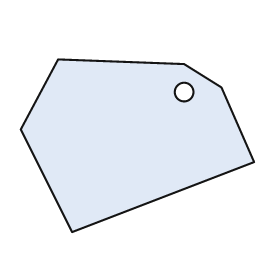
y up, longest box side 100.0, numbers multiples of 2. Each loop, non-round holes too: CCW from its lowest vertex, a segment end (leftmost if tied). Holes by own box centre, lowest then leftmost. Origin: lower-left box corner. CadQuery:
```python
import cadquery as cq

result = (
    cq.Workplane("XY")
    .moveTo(22.0, 0.0)
    .lineTo(100.0, 30.0)
    .lineTo(86.0, 62.0)
    .lineTo(70.0, 72.0)
    .lineTo(16.0, 74.0)
    .lineTo(0.0, 44.0)
    .close()
    .moveTo(70.0, 60.0)
    .circle(4.0)
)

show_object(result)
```